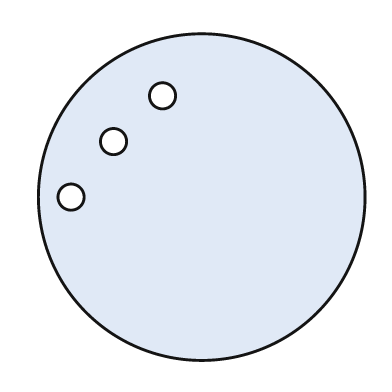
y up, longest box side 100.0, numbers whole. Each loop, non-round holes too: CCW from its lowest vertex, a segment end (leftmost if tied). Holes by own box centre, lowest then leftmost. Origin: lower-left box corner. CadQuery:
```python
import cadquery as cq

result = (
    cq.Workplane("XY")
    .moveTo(50.0, 50.0)
    .circle(50.0)
    .moveTo(10.0, 50.0)
    .circle(4.0)
    .moveTo(23.0, 67.0)
    .circle(4.0)
    .moveTo(38.0, 81.0)
    .circle(4.0)
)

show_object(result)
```